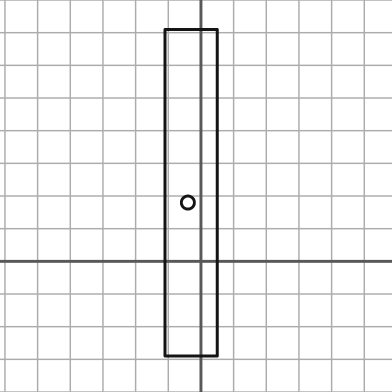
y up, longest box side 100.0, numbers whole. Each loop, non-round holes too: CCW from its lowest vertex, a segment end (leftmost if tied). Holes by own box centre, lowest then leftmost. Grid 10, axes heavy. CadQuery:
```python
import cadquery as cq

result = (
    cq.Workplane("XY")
    .moveTo(-11.0, -29.0)
    .lineTo(5.0, -29.0)
    .lineTo(5.0, 71.0)
    .lineTo(-11.0, 71.0)
    .close()
    .moveTo(-4.0, 18.0)
    .circle(2.0)
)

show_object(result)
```